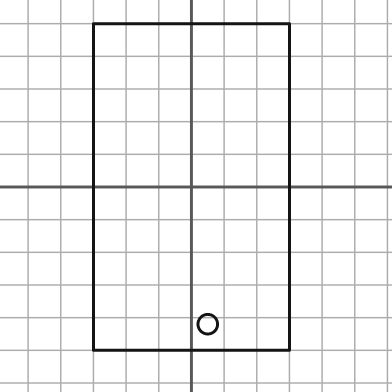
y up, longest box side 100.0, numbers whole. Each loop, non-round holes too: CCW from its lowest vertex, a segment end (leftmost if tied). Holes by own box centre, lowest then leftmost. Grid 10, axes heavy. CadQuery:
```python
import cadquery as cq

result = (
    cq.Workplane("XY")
    .moveTo(-30.0, -50.0)
    .lineTo(30.0, -50.0)
    .lineTo(30.0, 50.0)
    .lineTo(-30.0, 50.0)
    .close()
    .moveTo(5.0, -42.0)
    .circle(3.0)
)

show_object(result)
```